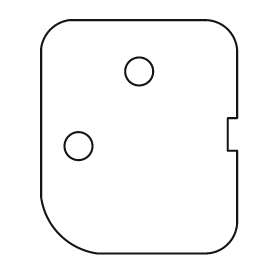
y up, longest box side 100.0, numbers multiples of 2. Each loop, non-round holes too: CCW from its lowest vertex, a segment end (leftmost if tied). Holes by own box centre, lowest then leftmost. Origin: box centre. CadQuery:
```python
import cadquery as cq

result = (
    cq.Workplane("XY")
    .moveTo(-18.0, -50.0)
    .lineTo(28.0, -50.0)
    .threePointArc((38.0, -46.0), (42.0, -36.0))
    .lineTo(42.0, -6.0)
    .lineTo(38.0, -6.0)
    .lineTo(38.0, 8.0)
    .lineTo(42.0, 8.0)
    .lineTo(42.0, 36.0)
    .threePointArc((38.0, 46.0), (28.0, 50.0))
    .lineTo(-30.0, 50.0)
    .threePointArc((-38.0, 46.0), (-42.0, 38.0))
    .lineTo(-42.0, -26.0)
    .threePointArc((-34.0, -42.0), (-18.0, -50.0))
    .close()
    .moveTo(-26.0, -4.0)
    .circle(6.0)
    .moveTo(0.0, 28.0)
    .circle(6.0)
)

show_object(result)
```